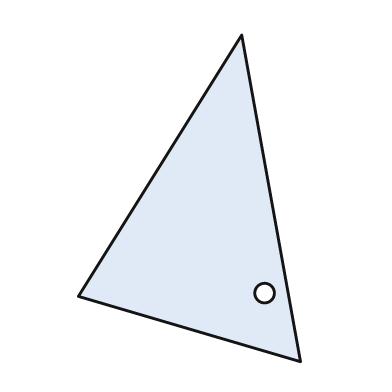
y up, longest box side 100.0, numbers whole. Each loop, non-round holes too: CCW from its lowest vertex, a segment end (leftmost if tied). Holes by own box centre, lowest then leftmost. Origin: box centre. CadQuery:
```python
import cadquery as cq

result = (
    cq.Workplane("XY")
    .moveTo(34.0, -50.0)
    .lineTo(16.0, 50.0)
    .lineTo(-34.0, -30.0)
    .close()
    .moveTo(23.0, -29.0)
    .circle(3.0)
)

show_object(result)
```